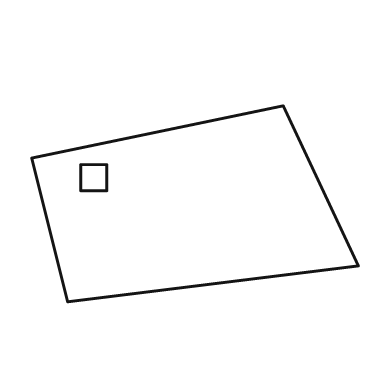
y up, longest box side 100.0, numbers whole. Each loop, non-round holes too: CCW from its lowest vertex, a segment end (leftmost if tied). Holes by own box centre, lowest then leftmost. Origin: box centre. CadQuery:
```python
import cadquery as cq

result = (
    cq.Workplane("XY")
    .moveTo(-39.0, -30.0)
    .lineTo(50.0, -19.0)
    .lineTo(27.0, 30.0)
    .lineTo(-50.0, 14.0)
    .close()
    .moveTo(-35.0, 4.0)
    .lineTo(-27.0, 4.0)
    .lineTo(-27.0, 12.0)
    .lineTo(-35.0, 12.0)
    .close()
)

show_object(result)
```